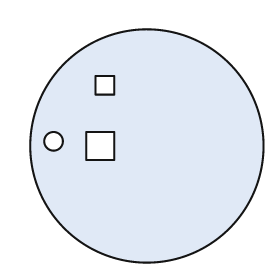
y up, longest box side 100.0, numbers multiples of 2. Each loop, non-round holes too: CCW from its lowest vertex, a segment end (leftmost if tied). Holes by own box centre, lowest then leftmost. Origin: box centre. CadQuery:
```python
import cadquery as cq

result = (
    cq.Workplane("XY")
    .moveTo(0.0, 0.0)
    .circle(50.0)
    .moveTo(-26.0, -6.0)
    .lineTo(-14.0, -6.0)
    .lineTo(-14.0, 6.0)
    .lineTo(-26.0, 6.0)
    .close()
    .moveTo(-40.0, 2.0)
    .circle(4.0)
    .moveTo(-22.0, 22.0)
    .lineTo(-14.0, 22.0)
    .lineTo(-14.0, 30.0)
    .lineTo(-22.0, 30.0)
    .close()
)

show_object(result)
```